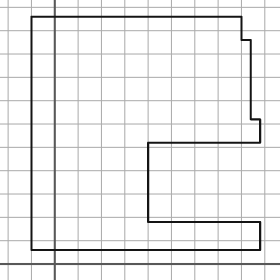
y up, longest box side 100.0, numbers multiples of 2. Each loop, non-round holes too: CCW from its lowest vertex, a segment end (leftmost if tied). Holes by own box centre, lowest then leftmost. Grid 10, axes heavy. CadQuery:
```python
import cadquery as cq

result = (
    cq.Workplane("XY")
    .moveTo(-10.0, 6.0)
    .lineTo(88.0, 6.0)
    .lineTo(88.0, 18.0)
    .lineTo(40.0, 18.0)
    .lineTo(40.0, 52.0)
    .lineTo(88.0, 52.0)
    .lineTo(88.0, 62.0)
    .lineTo(84.0, 62.0)
    .lineTo(84.0, 96.0)
    .lineTo(80.0, 96.0)
    .lineTo(80.0, 106.0)
    .lineTo(-10.0, 106.0)
    .close()
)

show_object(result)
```